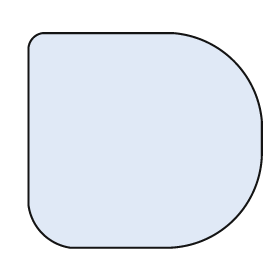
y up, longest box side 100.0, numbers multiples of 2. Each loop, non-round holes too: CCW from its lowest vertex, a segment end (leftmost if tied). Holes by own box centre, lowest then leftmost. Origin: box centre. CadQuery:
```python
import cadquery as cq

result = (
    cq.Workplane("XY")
    .moveTo(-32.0, -46.0)
    .lineTo(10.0, -46.0)
    .threePointArc((38.0, -34.0), (50.0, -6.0))
    .lineTo(50.0, 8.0)
    .threePointArc((38.0, 34.0), (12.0, 46.0))
    .lineTo(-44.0, 46.0)
    .threePointArc((-48.0, 44.0), (-50.0, 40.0))
    .lineTo(-50.0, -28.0)
    .threePointArc((-44.0, -40.0), (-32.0, -46.0))
    .close()
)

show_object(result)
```